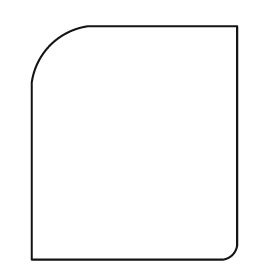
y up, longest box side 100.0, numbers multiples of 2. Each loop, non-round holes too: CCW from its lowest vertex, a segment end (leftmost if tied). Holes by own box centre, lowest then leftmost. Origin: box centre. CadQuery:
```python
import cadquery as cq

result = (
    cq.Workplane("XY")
    .moveTo(-44.0, -50.0)
    .lineTo(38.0, -50.0)
    .threePointArc((42.0, -48.0), (44.0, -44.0))
    .lineTo(44.0, 50.0)
    .lineTo(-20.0, 50.0)
    .threePointArc((-36.0, 42.0), (-44.0, 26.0))
    .close()
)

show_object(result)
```